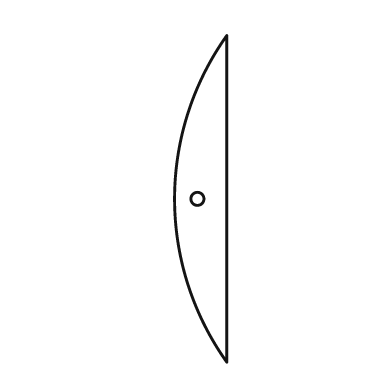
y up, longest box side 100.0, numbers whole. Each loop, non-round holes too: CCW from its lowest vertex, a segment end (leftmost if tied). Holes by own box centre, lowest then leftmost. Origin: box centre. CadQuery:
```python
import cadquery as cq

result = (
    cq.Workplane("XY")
    .moveTo(8.0, -50.0)
    .lineTo(8.0, 50.0)
    .threePointArc((-8.0, 0.0), (8.0, -50.0))
    .close()
    .moveTo(-1.0, 0.0)
    .circle(2.0)
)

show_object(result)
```